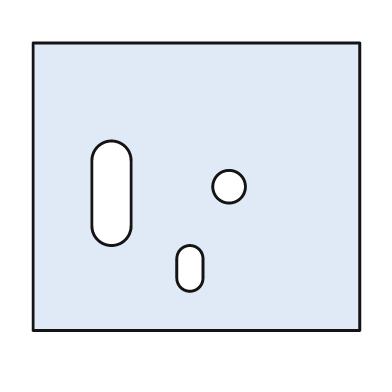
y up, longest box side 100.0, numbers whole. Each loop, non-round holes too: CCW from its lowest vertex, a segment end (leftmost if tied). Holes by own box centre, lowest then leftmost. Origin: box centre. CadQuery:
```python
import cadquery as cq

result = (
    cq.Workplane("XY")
    .moveTo(-50.0, -44.0)
    .lineTo(50.0, -44.0)
    .lineTo(50.0, 44.0)
    .lineTo(-50.0, 44.0)
    .close()
    .moveTo(-6.0, -28.0)
    .threePointArc((-2.0, -32.0), (2.0, -28.0))
    .lineTo(2.0, -22.0)
    .threePointArc((-2.0, -18.0), (-6.0, -22.0))
    .close()
    .moveTo(-32.0, -12.0)
    .threePointArc((-26.0, -18.0), (-20.0, -12.0))
    .lineTo(-20.0, 8.0)
    .threePointArc((-26.0, 14.0), (-32.0, 8.0))
    .close()
    .moveTo(10.0, 0.0)
    .circle(5.0)
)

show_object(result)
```